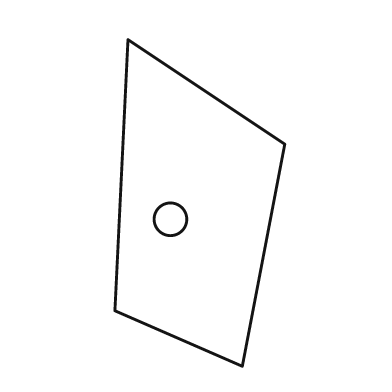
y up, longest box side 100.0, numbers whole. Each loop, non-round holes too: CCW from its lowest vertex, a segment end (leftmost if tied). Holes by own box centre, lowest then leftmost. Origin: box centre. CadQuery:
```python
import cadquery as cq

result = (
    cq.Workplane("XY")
    .moveTo(13.0, -50.0)
    .lineTo(26.0, 18.0)
    .lineTo(-22.0, 50.0)
    .lineTo(-26.0, -33.0)
    .close()
    .moveTo(-9.0, -5.0)
    .circle(5.0)
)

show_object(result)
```